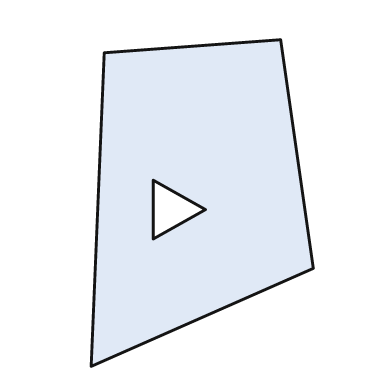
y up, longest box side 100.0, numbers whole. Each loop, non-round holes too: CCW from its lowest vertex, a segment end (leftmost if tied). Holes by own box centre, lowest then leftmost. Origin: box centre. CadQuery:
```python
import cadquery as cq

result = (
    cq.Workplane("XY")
    .moveTo(-34.0, -50.0)
    .lineTo(34.0, -20.0)
    .lineTo(24.0, 50.0)
    .lineTo(-30.0, 46.0)
    .close()
    .moveTo(-15.0, -11.0)
    .lineTo(1.0, -2.0)
    .lineTo(-15.0, 7.0)
    .close()
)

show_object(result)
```